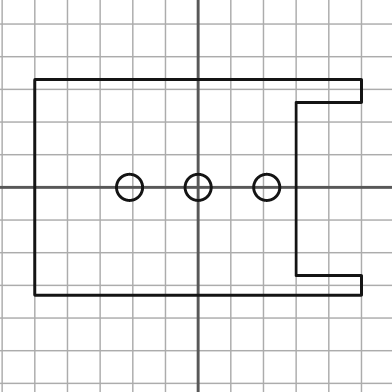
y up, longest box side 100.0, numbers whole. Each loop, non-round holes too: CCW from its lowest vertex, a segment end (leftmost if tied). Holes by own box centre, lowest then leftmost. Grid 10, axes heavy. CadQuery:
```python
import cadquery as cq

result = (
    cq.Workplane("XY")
    .moveTo(-50.0, -33.0)
    .lineTo(50.0, -33.0)
    .lineTo(50.0, -27.0)
    .lineTo(30.0, -27.0)
    .lineTo(30.0, 26.0)
    .lineTo(50.0, 26.0)
    .lineTo(50.0, 33.0)
    .lineTo(-50.0, 33.0)
    .close()
    .moveTo(-21.0, 0.0)
    .circle(4.0)
    .moveTo(0.0, 0.0)
    .circle(4.0)
    .moveTo(21.0, 0.0)
    .circle(4.0)
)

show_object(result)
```